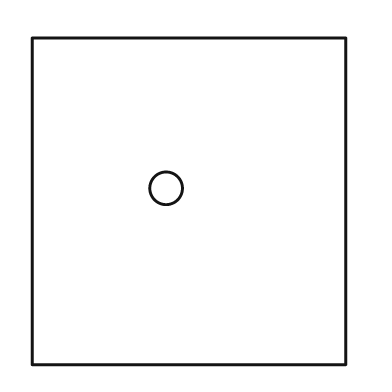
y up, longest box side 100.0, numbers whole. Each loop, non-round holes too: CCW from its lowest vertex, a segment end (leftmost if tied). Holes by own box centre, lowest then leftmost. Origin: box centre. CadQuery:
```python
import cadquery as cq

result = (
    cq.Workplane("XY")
    .moveTo(-48.0, -50.0)
    .lineTo(48.0, -50.0)
    .lineTo(48.0, 50.0)
    .lineTo(-48.0, 50.0)
    .close()
    .moveTo(-7.0, 4.0)
    .circle(5.0)
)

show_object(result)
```